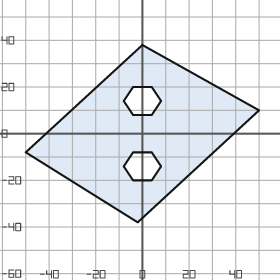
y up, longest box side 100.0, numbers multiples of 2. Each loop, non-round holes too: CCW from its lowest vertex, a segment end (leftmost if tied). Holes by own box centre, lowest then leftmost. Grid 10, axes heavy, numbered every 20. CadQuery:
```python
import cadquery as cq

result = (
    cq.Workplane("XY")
    .moveTo(-2.0, -38.0)
    .lineTo(50.0, 10.0)
    .lineTo(0.0, 38.0)
    .lineTo(-50.0, -8.0)
    .close()
    .moveTo(-4.0, -20.0)
    .lineTo(4.0, -20.0)
    .lineTo(8.0, -14.0)
    .lineTo(4.0, -8.0)
    .lineTo(-4.0, -8.0)
    .lineTo(-8.0, -14.0)
    .close()
    .moveTo(-4.0, 8.0)
    .lineTo(4.0, 8.0)
    .lineTo(8.0, 14.0)
    .lineTo(4.0, 20.0)
    .lineTo(-4.0, 20.0)
    .lineTo(-8.0, 14.0)
    .close()
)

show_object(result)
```